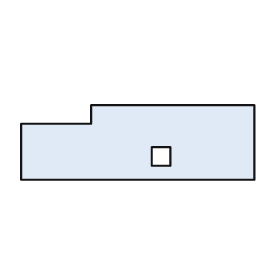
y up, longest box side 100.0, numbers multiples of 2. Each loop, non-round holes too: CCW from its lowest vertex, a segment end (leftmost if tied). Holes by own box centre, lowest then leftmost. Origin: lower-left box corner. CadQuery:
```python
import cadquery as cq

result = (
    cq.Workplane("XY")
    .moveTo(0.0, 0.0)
    .lineTo(100.0, 0.0)
    .lineTo(100.0, 32.0)
    .lineTo(30.0, 32.0)
    .lineTo(30.0, 24.0)
    .lineTo(0.0, 24.0)
    .close()
    .moveTo(56.0, 6.0)
    .lineTo(64.0, 6.0)
    .lineTo(64.0, 14.0)
    .lineTo(56.0, 14.0)
    .close()
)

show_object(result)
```